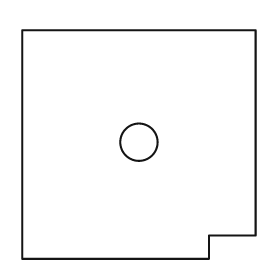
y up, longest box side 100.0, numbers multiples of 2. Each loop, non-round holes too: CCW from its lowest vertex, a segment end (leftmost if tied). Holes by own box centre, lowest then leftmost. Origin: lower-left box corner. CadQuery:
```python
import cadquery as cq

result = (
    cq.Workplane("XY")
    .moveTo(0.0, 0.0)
    .lineTo(80.0, 0.0)
    .lineTo(80.0, 10.0)
    .lineTo(100.0, 10.0)
    .lineTo(100.0, 98.0)
    .lineTo(0.0, 98.0)
    .close()
    .moveTo(50.0, 50.0)
    .circle(8.0)
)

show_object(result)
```